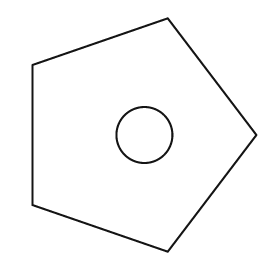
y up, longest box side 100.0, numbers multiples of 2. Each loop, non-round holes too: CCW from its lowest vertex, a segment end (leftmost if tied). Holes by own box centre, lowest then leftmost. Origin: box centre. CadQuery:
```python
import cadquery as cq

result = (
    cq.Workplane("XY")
    .moveTo(10.0, -50.0)
    .lineTo(48.0, 0.0)
    .lineTo(10.0, 50.0)
    .lineTo(-48.0, 30.0)
    .lineTo(-48.0, -30.0)
    .close()
    .moveTo(0.0, 0.0)
    .circle(12.0)
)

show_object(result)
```